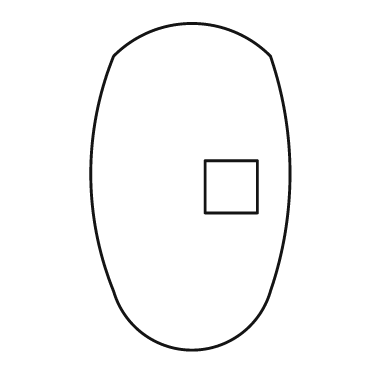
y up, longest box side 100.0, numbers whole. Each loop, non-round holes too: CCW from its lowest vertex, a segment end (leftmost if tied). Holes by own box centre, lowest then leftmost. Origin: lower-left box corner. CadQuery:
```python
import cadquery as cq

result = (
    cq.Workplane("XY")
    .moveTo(7.0, 18.0)
    .threePointArc((31.0, 0.0), (55.0, 18.0))
    .threePointArc((61.0, 54.0), (55.0, 90.0))
    .threePointArc((31.0, 100.0), (7.0, 90.0))
    .threePointArc((0.0, 54.0), (7.0, 18.0))
    .close()
    .moveTo(35.0, 42.0)
    .lineTo(51.0, 42.0)
    .lineTo(51.0, 58.0)
    .lineTo(35.0, 58.0)
    .close()
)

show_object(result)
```